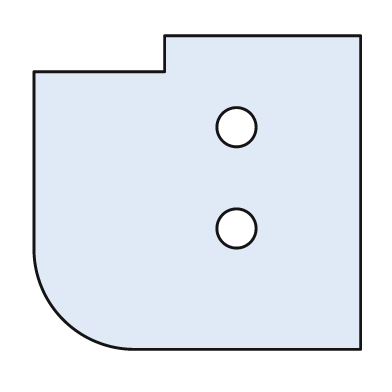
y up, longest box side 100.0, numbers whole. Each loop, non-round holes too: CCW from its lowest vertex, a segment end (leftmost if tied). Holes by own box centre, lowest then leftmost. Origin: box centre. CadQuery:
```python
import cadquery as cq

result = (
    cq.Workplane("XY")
    .moveTo(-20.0, -48.0)
    .lineTo(50.0, -48.0)
    .lineTo(50.0, 48.0)
    .lineTo(-10.0, 48.0)
    .lineTo(-10.0, 37.0)
    .lineTo(-50.0, 37.0)
    .lineTo(-50.0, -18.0)
    .threePointArc((-41.0, -39.0), (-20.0, -48.0))
    .close()
    .moveTo(12.0, -11.0)
    .circle(6.0)
    .moveTo(12.0, 20.0)
    .circle(6.0)
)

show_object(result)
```